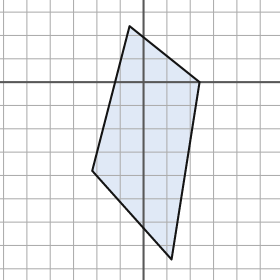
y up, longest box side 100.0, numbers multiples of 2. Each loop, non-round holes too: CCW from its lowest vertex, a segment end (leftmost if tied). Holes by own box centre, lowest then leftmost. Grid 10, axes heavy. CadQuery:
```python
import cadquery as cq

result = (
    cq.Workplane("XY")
    .moveTo(12.0, -76.0)
    .lineTo(24.0, 0.0)
    .lineTo(-6.0, 24.0)
    .lineTo(-22.0, -38.0)
    .close()
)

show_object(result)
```